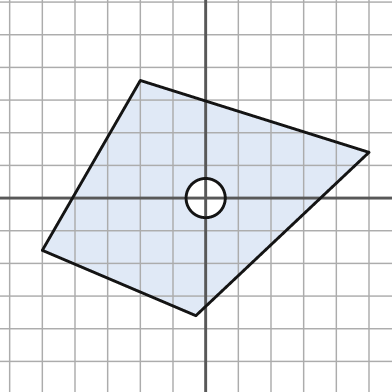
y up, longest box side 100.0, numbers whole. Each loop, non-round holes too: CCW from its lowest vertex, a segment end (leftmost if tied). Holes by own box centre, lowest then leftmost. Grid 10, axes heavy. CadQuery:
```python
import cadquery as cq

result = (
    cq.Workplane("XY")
    .moveTo(-3.0, -36.0)
    .lineTo(50.0, 14.0)
    .lineTo(-20.0, 36.0)
    .lineTo(-50.0, -16.0)
    .close()
    .moveTo(0.0, 0.0)
    .circle(6.0)
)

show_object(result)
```